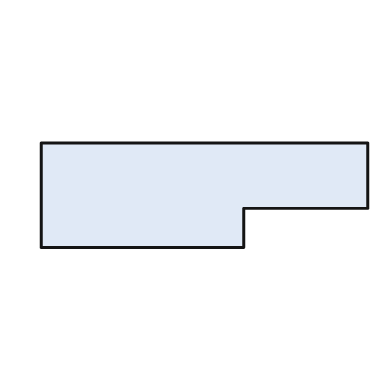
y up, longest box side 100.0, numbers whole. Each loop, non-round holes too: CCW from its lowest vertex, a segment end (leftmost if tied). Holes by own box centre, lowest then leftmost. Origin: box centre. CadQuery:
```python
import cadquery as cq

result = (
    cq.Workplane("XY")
    .moveTo(-50.0, -16.0)
    .lineTo(12.0, -16.0)
    .lineTo(12.0, -4.0)
    .lineTo(50.0, -4.0)
    .lineTo(50.0, 16.0)
    .lineTo(-50.0, 16.0)
    .close()
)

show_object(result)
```